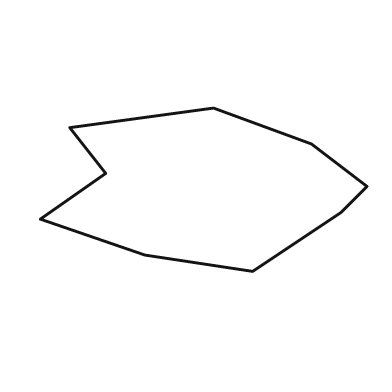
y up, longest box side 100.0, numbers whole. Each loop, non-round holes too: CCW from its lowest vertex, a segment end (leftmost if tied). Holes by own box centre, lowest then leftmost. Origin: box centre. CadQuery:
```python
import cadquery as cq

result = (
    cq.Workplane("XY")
    .moveTo(15.0, -25.0)
    .lineTo(42.0, -7.0)
    .lineTo(50.0, 1.0)
    .lineTo(33.0, 14.0)
    .lineTo(3.0, 25.0)
    .lineTo(-41.0, 19.0)
    .lineTo(-30.0, 5.0)
    .lineTo(-50.0, -9.0)
    .lineTo(-18.0, -20.0)
    .close()
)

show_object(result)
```